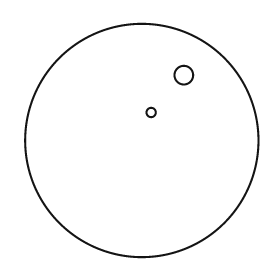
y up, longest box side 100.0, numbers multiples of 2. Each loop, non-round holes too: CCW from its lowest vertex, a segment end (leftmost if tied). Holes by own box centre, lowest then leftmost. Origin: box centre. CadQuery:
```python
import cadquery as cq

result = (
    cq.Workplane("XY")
    .moveTo(0.0, 0.0)
    .circle(50.0)
    .moveTo(4.0, 12.0)
    .circle(2.0)
    .moveTo(18.0, 28.0)
    .circle(4.0)
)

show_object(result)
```